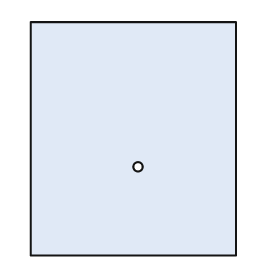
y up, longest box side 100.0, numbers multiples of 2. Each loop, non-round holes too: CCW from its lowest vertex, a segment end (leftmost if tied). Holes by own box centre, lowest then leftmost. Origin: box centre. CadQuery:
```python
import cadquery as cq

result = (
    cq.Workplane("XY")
    .moveTo(-44.0, -50.0)
    .lineTo(44.0, -50.0)
    .lineTo(44.0, 50.0)
    .lineTo(-44.0, 50.0)
    .close()
    .moveTo(2.0, -12.0)
    .circle(2.0)
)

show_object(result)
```